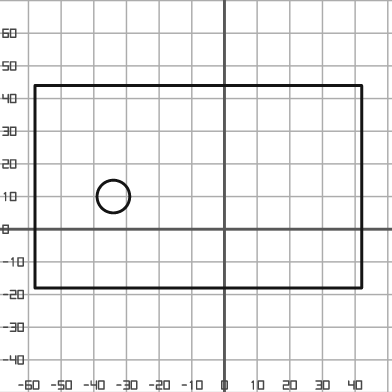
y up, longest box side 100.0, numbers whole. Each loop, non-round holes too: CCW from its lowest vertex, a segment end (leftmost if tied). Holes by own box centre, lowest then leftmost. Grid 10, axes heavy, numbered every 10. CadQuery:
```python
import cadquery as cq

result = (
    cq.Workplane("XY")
    .moveTo(-58.0, -18.0)
    .lineTo(42.0, -18.0)
    .lineTo(42.0, 44.0)
    .lineTo(-58.0, 44.0)
    .close()
    .moveTo(-34.0, 10.0)
    .circle(5.0)
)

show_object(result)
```